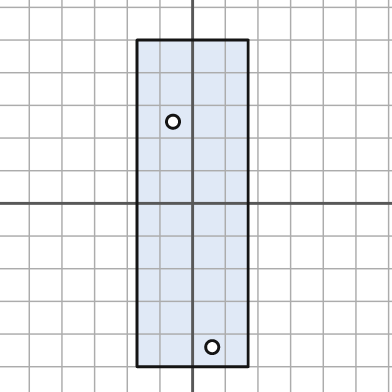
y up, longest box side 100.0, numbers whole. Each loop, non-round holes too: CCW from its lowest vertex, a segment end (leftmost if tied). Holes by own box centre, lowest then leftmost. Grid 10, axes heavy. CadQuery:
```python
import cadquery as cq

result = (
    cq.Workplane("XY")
    .moveTo(-17.0, -50.0)
    .lineTo(17.0, -50.0)
    .lineTo(17.0, 50.0)
    .lineTo(-17.0, 50.0)
    .close()
    .moveTo(6.0, -44.0)
    .circle(2.0)
    .moveTo(-6.0, 25.0)
    .circle(2.0)
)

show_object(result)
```